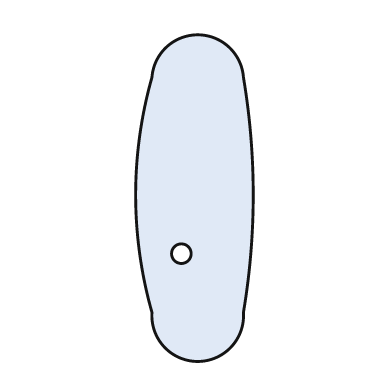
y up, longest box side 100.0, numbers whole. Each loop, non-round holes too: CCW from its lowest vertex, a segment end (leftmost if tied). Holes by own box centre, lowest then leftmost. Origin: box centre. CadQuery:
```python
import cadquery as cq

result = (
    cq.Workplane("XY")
    .moveTo(-13.0, -35.0)
    .threePointArc((1.0, -50.0), (15.0, -35.0))
    .threePointArc((18.0, 1.0), (15.0, 37.0))
    .threePointArc((1.0, 50.0), (-13.0, 37.0))
    .threePointArc((-18.0, 1.0), (-13.0, -35.0))
    .close()
    .moveTo(-4.0, -17.0)
    .circle(3.0)
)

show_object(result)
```